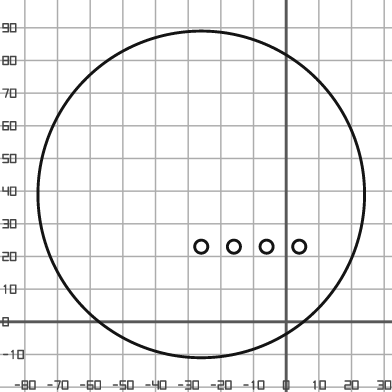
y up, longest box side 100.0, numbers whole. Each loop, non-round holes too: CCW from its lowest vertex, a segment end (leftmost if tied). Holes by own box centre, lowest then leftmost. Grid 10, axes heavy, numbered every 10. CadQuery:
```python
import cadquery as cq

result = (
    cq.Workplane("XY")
    .moveTo(-26.0, 39.0)
    .circle(50.0)
    .moveTo(-26.0, 23.0)
    .circle(2.0)
    .moveTo(-16.0, 23.0)
    .circle(2.0)
    .moveTo(-6.0, 23.0)
    .circle(2.0)
    .moveTo(4.0, 23.0)
    .circle(2.0)
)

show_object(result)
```